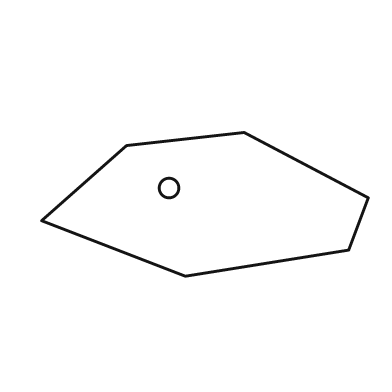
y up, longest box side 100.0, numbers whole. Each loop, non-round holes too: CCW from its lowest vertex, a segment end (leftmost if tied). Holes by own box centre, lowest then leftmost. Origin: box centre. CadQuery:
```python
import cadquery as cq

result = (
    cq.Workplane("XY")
    .moveTo(-6.0, -22.0)
    .lineTo(44.0, -14.0)
    .lineTo(50.0, 2.0)
    .lineTo(12.0, 22.0)
    .lineTo(-24.0, 18.0)
    .lineTo(-50.0, -5.0)
    .close()
    .moveTo(-11.0, 5.0)
    .circle(3.0)
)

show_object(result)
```